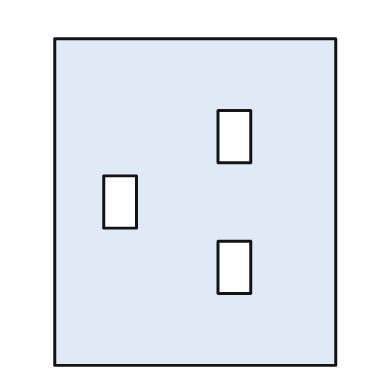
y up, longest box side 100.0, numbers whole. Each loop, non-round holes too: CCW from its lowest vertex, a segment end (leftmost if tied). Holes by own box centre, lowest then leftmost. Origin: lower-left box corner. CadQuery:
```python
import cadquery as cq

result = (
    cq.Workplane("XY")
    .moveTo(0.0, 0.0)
    .lineTo(86.0, 0.0)
    .lineTo(86.0, 100.0)
    .lineTo(0.0, 100.0)
    .close()
    .moveTo(50.0, 22.0)
    .lineTo(60.0, 22.0)
    .lineTo(60.0, 38.0)
    .lineTo(50.0, 38.0)
    .close()
    .moveTo(15.0, 42.0)
    .lineTo(25.0, 42.0)
    .lineTo(25.0, 58.0)
    .lineTo(15.0, 58.0)
    .close()
    .moveTo(50.0, 62.0)
    .lineTo(60.0, 62.0)
    .lineTo(60.0, 78.0)
    .lineTo(50.0, 78.0)
    .close()
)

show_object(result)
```